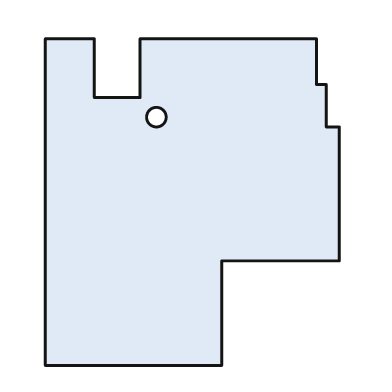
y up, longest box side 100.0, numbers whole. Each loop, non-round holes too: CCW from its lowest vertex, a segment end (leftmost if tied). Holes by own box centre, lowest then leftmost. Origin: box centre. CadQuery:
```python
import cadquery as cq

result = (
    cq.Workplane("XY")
    .moveTo(-45.0, -50.0)
    .lineTo(9.0, -50.0)
    .lineTo(9.0, -18.0)
    .lineTo(45.0, -18.0)
    .lineTo(45.0, 23.0)
    .lineTo(41.0, 23.0)
    .lineTo(41.0, 36.0)
    .lineTo(38.0, 36.0)
    .lineTo(38.0, 50.0)
    .lineTo(-16.0, 50.0)
    .lineTo(-16.0, 32.0)
    .lineTo(-30.0, 32.0)
    .lineTo(-30.0, 50.0)
    .lineTo(-45.0, 50.0)
    .close()
    .moveTo(-11.0, 26.0)
    .circle(3.0)
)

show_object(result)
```